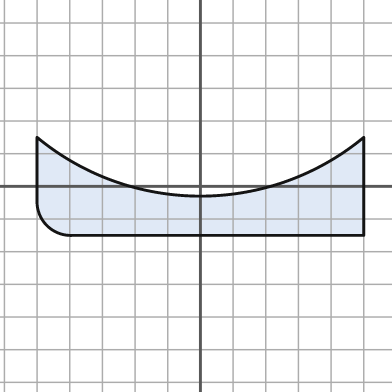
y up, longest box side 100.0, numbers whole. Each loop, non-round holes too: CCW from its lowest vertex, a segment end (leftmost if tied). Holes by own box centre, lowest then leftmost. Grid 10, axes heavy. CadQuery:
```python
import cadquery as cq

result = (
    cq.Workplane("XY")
    .moveTo(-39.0, -15.0)
    .lineTo(50.0, -15.0)
    .lineTo(50.0, 15.0)
    .threePointArc((0.0, -3.0), (-50.0, 15.0))
    .lineTo(-50.0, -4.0)
    .threePointArc((-47.0, -12.0), (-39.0, -15.0))
    .close()
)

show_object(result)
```